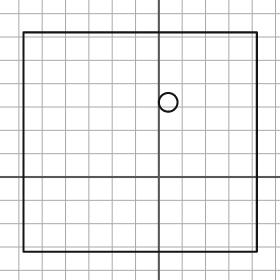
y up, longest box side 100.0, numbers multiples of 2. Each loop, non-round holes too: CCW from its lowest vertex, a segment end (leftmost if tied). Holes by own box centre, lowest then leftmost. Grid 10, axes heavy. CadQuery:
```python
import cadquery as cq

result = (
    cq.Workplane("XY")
    .moveTo(-58.0, -32.0)
    .lineTo(42.0, -32.0)
    .lineTo(42.0, 62.0)
    .lineTo(-58.0, 62.0)
    .close()
    .moveTo(4.0, 32.0)
    .circle(4.0)
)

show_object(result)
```